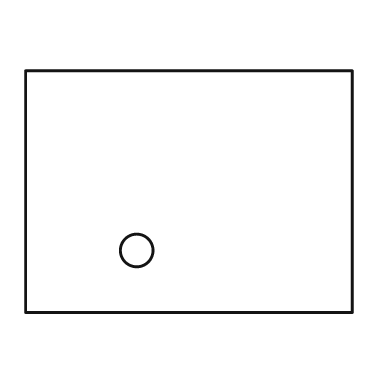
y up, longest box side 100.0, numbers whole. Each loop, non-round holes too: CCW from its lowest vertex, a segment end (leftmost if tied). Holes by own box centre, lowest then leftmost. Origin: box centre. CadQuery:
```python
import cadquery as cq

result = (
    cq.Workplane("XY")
    .moveTo(-50.0, -37.0)
    .lineTo(50.0, -37.0)
    .lineTo(50.0, 37.0)
    .lineTo(-50.0, 37.0)
    .close()
    .moveTo(-16.0, -18.0)
    .circle(5.0)
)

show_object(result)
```